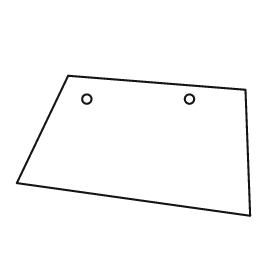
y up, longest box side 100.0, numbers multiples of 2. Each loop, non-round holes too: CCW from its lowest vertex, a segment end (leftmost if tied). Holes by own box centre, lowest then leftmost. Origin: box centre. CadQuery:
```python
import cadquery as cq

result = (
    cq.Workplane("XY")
    .moveTo(50.0, -30.0)
    .lineTo(48.0, 24.0)
    .lineTo(-28.0, 30.0)
    .lineTo(-50.0, -16.0)
    .close()
    .moveTo(-20.0, 20.0)
    .circle(2.0)
    .moveTo(24.0, 20.0)
    .circle(2.0)
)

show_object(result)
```